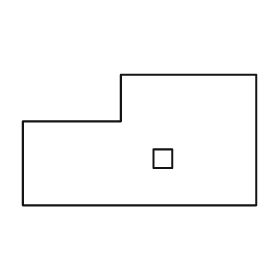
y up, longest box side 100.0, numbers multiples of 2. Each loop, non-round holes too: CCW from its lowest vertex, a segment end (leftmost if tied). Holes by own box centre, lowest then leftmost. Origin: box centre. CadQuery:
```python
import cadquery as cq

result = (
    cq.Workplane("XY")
    .moveTo(-50.0, -28.0)
    .lineTo(50.0, -28.0)
    .lineTo(50.0, 28.0)
    .lineTo(-8.0, 28.0)
    .lineTo(-8.0, 8.0)
    .lineTo(-50.0, 8.0)
    .close()
    .moveTo(6.0, -12.0)
    .lineTo(14.0, -12.0)
    .lineTo(14.0, -4.0)
    .lineTo(6.0, -4.0)
    .close()
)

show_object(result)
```